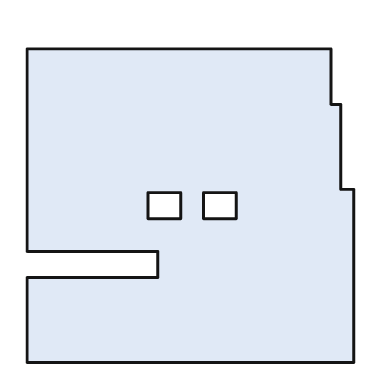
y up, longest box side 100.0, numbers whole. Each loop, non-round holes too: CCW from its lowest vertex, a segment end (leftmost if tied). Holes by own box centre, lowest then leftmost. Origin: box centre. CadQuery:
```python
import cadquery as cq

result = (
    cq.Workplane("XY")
    .moveTo(-50.0, -48.0)
    .lineTo(50.0, -48.0)
    .lineTo(50.0, 5.0)
    .lineTo(46.0, 5.0)
    .lineTo(46.0, 31.0)
    .lineTo(43.0, 31.0)
    .lineTo(43.0, 48.0)
    .lineTo(-50.0, 48.0)
    .lineTo(-50.0, -14.0)
    .lineTo(-10.0, -14.0)
    .lineTo(-10.0, -22.0)
    .lineTo(-50.0, -22.0)
    .close()
    .moveTo(-13.0, -4.0)
    .lineTo(-3.0, -4.0)
    .lineTo(-3.0, 4.0)
    .lineTo(-13.0, 4.0)
    .close()
    .moveTo(4.0, -4.0)
    .lineTo(14.0, -4.0)
    .lineTo(14.0, 4.0)
    .lineTo(4.0, 4.0)
    .close()
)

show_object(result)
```